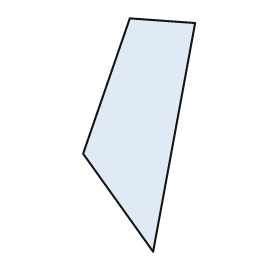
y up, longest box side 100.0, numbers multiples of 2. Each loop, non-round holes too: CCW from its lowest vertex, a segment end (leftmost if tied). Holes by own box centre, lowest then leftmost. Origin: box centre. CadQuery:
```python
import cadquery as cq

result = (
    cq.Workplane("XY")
    .moveTo(6.0, -50.0)
    .lineTo(24.0, 48.0)
    .lineTo(-4.0, 50.0)
    .lineTo(-24.0, -8.0)
    .close()
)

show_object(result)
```